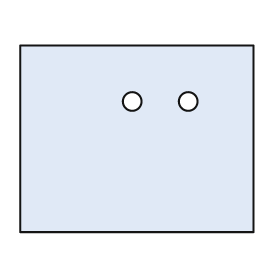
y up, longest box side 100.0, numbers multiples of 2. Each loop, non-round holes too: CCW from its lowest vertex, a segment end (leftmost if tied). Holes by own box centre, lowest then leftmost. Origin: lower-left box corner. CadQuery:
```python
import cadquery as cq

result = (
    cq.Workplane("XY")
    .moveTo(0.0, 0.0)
    .lineTo(100.0, 0.0)
    .lineTo(100.0, 80.0)
    .lineTo(0.0, 80.0)
    .close()
    .moveTo(48.0, 56.0)
    .circle(4.0)
    .moveTo(72.0, 56.0)
    .circle(4.0)
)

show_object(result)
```